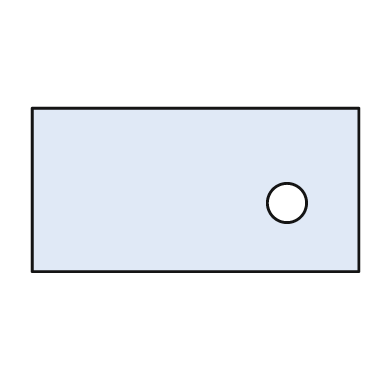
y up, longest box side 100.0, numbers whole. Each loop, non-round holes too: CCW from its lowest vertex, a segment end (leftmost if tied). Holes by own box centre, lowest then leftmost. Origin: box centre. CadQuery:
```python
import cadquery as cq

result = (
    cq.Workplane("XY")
    .moveTo(-50.0, -25.0)
    .lineTo(50.0, -25.0)
    .lineTo(50.0, 25.0)
    .lineTo(-50.0, 25.0)
    .close()
    .moveTo(28.0, -4.0)
    .circle(6.0)
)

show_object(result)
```